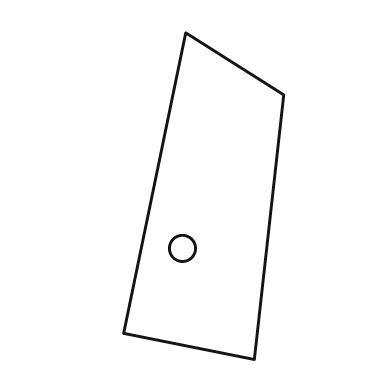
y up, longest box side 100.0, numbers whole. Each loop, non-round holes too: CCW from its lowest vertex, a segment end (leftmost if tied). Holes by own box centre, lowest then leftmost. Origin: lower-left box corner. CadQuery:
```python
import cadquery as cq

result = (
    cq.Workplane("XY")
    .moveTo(40.0, 0.0)
    .lineTo(49.0, 81.0)
    .lineTo(19.0, 100.0)
    .lineTo(0.0, 8.0)
    .close()
    .moveTo(18.0, 34.0)
    .circle(4.0)
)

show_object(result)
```